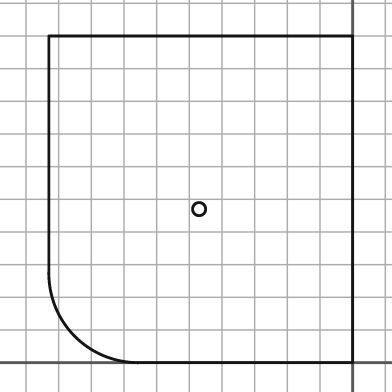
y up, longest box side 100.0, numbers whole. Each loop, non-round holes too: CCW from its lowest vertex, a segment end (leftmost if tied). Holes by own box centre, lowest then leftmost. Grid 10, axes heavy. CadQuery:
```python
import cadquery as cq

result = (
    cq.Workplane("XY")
    .moveTo(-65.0, 0.0)
    .lineTo(0.0, 0.0)
    .lineTo(0.0, 100.0)
    .lineTo(-93.0, 100.0)
    .lineTo(-93.0, 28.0)
    .threePointArc((-85.0, 8.0), (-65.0, 0.0))
    .close()
    .moveTo(-47.0, 47.0)
    .circle(2.0)
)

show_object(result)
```